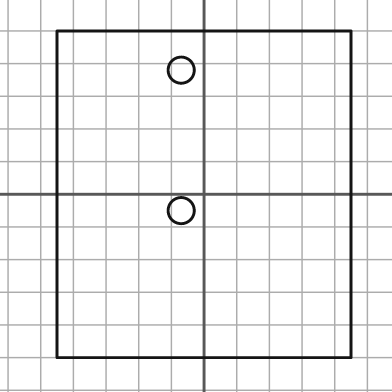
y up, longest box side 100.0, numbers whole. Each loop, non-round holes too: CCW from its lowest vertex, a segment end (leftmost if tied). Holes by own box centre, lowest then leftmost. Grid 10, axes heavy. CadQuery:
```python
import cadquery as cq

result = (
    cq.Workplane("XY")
    .moveTo(-45.0, -50.0)
    .lineTo(45.0, -50.0)
    .lineTo(45.0, 50.0)
    .lineTo(-45.0, 50.0)
    .close()
    .moveTo(-7.0, -5.0)
    .circle(4.0)
    .moveTo(-7.0, 38.0)
    .circle(4.0)
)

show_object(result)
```